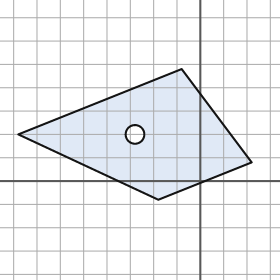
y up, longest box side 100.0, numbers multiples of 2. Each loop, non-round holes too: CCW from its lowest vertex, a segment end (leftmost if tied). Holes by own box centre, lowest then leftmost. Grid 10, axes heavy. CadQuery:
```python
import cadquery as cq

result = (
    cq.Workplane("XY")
    .moveTo(-18.0, -8.0)
    .lineTo(22.0, 8.0)
    .lineTo(-8.0, 48.0)
    .lineTo(-78.0, 20.0)
    .close()
    .moveTo(-28.0, 20.0)
    .circle(4.0)
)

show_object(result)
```